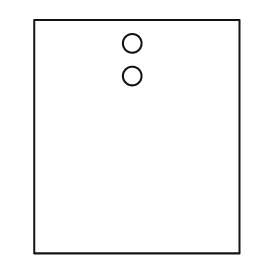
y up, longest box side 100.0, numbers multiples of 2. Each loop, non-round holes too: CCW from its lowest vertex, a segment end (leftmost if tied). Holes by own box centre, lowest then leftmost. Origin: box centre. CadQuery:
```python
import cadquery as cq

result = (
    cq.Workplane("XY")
    .moveTo(-44.0, -50.0)
    .lineTo(44.0, -50.0)
    .lineTo(44.0, 50.0)
    .lineTo(-44.0, 50.0)
    .close()
    .moveTo(-2.0, 26.0)
    .circle(4.0)
    .moveTo(-2.0, 40.0)
    .circle(4.0)
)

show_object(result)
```